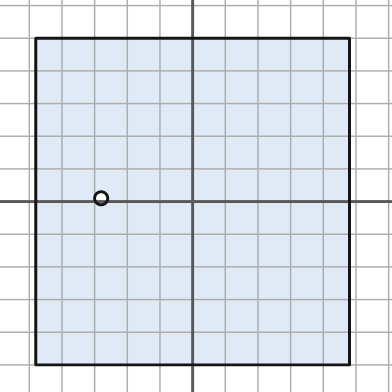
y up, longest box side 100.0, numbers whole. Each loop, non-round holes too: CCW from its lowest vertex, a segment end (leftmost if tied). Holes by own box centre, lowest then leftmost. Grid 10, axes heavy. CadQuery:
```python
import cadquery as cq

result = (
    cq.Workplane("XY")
    .moveTo(-48.0, -50.0)
    .lineTo(48.0, -50.0)
    .lineTo(48.0, 50.0)
    .lineTo(-48.0, 50.0)
    .close()
    .moveTo(-28.0, 1.0)
    .circle(2.0)
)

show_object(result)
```